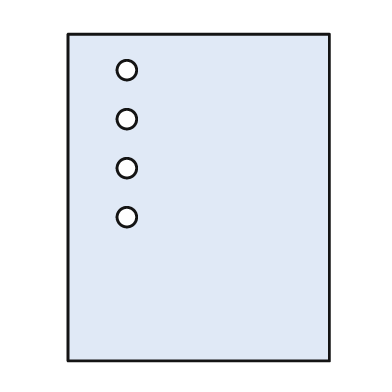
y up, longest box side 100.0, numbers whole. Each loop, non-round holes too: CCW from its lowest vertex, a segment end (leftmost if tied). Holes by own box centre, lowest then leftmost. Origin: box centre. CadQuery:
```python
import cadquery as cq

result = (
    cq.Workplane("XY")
    .moveTo(-40.0, -50.0)
    .lineTo(40.0, -50.0)
    .lineTo(40.0, 50.0)
    .lineTo(-40.0, 50.0)
    .close()
    .moveTo(-22.0, -6.0)
    .circle(3.0)
    .moveTo(-22.0, 9.0)
    .circle(3.0)
    .moveTo(-22.0, 24.0)
    .circle(3.0)
    .moveTo(-22.0, 39.0)
    .circle(3.0)
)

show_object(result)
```